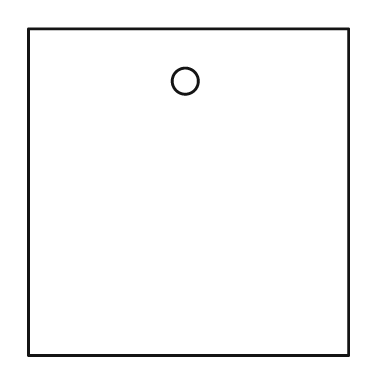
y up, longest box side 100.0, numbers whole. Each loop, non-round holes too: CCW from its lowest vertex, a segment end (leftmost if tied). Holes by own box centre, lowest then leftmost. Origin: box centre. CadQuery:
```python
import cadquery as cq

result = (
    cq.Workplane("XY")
    .moveTo(-49.0, -50.0)
    .lineTo(49.0, -50.0)
    .lineTo(49.0, 50.0)
    .lineTo(-49.0, 50.0)
    .close()
    .moveTo(-1.0, 34.0)
    .circle(4.0)
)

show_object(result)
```